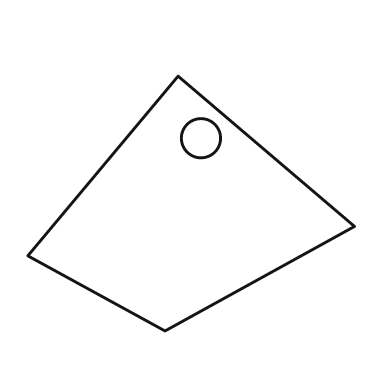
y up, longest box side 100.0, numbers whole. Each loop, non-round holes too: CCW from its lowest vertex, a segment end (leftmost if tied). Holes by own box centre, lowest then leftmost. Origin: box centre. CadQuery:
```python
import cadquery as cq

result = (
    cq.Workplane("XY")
    .moveTo(-8.0, -39.0)
    .lineTo(50.0, -7.0)
    .lineTo(-4.0, 39.0)
    .lineTo(-50.0, -16.0)
    .close()
    .moveTo(3.0, 20.0)
    .circle(6.0)
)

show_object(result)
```